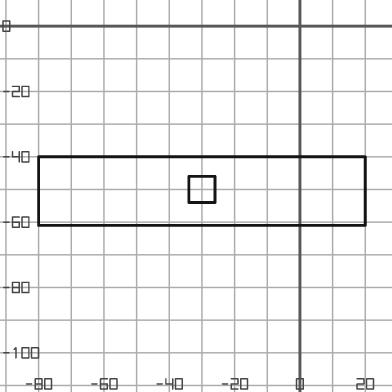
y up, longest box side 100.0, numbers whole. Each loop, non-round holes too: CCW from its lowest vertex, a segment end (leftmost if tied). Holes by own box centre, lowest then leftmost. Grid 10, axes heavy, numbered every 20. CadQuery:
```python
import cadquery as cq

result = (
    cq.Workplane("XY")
    .moveTo(-80.0, -61.0)
    .lineTo(20.0, -61.0)
    .lineTo(20.0, -40.0)
    .lineTo(-80.0, -40.0)
    .close()
    .moveTo(-34.0, -54.0)
    .lineTo(-26.0, -54.0)
    .lineTo(-26.0, -46.0)
    .lineTo(-34.0, -46.0)
    .close()
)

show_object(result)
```